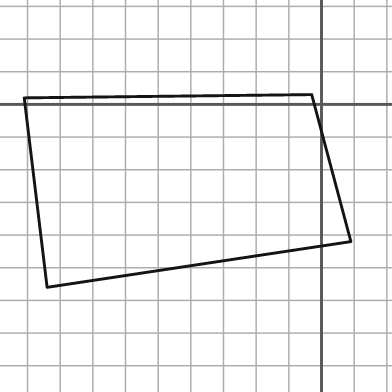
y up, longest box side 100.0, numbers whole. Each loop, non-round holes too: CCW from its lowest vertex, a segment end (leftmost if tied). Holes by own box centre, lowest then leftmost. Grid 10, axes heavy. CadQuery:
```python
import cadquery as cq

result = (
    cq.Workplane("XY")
    .moveTo(-84.0, -56.0)
    .lineTo(9.0, -42.0)
    .lineTo(-3.0, 3.0)
    .lineTo(-91.0, 2.0)
    .close()
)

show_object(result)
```